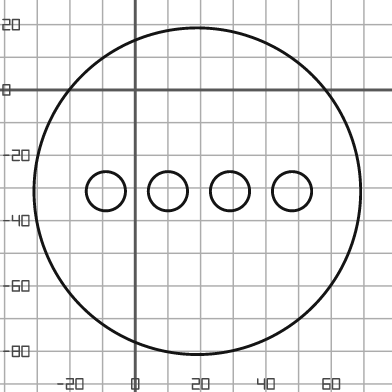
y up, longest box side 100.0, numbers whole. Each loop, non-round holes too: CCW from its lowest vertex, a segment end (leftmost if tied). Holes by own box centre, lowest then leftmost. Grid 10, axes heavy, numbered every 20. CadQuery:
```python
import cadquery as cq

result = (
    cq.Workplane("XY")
    .moveTo(19.0, -31.0)
    .circle(50.0)
    .moveTo(-9.0, -31.0)
    .circle(6.0)
    .moveTo(10.0, -31.0)
    .circle(6.0)
    .moveTo(29.0, -31.0)
    .circle(6.0)
    .moveTo(48.0, -31.0)
    .circle(6.0)
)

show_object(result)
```